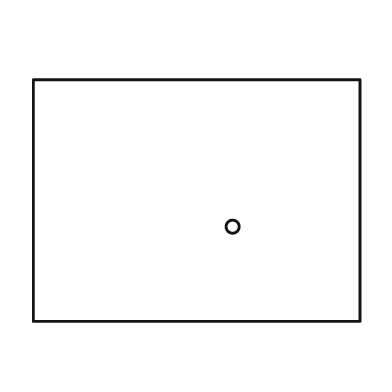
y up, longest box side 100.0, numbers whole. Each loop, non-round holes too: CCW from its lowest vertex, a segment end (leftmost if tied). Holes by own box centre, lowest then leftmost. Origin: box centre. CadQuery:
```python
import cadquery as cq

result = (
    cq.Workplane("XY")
    .moveTo(-50.0, -37.0)
    .lineTo(50.0, -37.0)
    .lineTo(50.0, 37.0)
    .lineTo(-50.0, 37.0)
    .close()
    .moveTo(11.0, -8.0)
    .circle(2.0)
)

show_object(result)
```